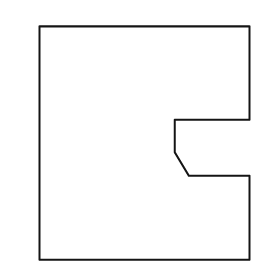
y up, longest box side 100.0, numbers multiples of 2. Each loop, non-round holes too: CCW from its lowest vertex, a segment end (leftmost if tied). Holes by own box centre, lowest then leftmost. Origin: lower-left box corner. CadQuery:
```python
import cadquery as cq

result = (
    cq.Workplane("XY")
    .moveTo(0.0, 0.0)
    .lineTo(90.0, 0.0)
    .lineTo(90.0, 36.0)
    .lineTo(64.0, 36.0)
    .lineTo(58.0, 46.0)
    .lineTo(58.0, 60.0)
    .lineTo(90.0, 60.0)
    .lineTo(90.0, 100.0)
    .lineTo(0.0, 100.0)
    .close()
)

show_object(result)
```